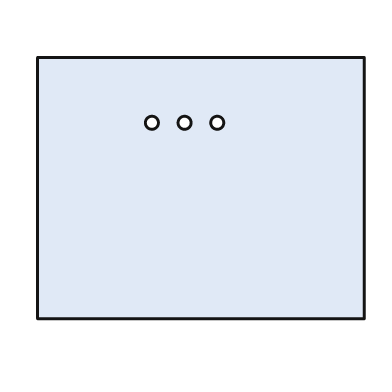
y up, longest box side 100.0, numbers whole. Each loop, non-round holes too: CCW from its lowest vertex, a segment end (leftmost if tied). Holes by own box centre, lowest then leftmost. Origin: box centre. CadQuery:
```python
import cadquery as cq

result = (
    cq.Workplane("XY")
    .moveTo(-50.0, -40.0)
    .lineTo(50.0, -40.0)
    .lineTo(50.0, 40.0)
    .lineTo(-50.0, 40.0)
    .close()
    .moveTo(-15.0, 20.0)
    .circle(2.0)
    .moveTo(-5.0, 20.0)
    .circle(2.0)
    .moveTo(5.0, 20.0)
    .circle(2.0)
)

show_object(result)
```